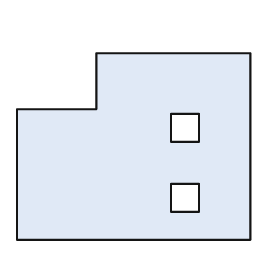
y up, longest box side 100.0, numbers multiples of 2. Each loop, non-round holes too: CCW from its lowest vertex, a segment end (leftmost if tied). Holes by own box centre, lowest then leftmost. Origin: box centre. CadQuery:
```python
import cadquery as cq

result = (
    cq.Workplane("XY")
    .moveTo(-50.0, -40.0)
    .lineTo(50.0, -40.0)
    .lineTo(50.0, 40.0)
    .lineTo(-16.0, 40.0)
    .lineTo(-16.0, 16.0)
    .lineTo(-50.0, 16.0)
    .close()
    .moveTo(16.0, -28.0)
    .lineTo(28.0, -28.0)
    .lineTo(28.0, -16.0)
    .lineTo(16.0, -16.0)
    .close()
    .moveTo(16.0, 2.0)
    .lineTo(28.0, 2.0)
    .lineTo(28.0, 14.0)
    .lineTo(16.0, 14.0)
    .close()
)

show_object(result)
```